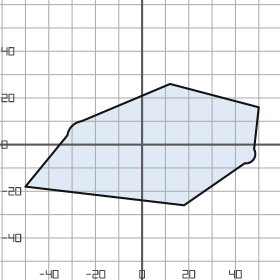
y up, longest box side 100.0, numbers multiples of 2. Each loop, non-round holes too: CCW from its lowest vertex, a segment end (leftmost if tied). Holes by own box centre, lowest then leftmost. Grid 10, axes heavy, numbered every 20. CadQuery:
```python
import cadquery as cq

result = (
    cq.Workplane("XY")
    .moveTo(18.0, -26.0)
    .lineTo(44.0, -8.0)
    .threePointArc((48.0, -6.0), (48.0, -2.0))
    .lineTo(50.0, 16.0)
    .lineTo(12.0, 26.0)
    .lineTo(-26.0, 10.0)
    .threePointArc((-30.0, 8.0), (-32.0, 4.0))
    .lineTo(-50.0, -18.0)
    .close()
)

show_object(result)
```